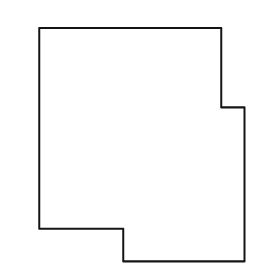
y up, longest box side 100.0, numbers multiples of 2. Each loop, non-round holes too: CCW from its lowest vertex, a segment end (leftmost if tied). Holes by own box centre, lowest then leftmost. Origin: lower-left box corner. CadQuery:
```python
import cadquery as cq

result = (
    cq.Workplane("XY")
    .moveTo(36.0, 0.0)
    .lineTo(88.0, 0.0)
    .lineTo(88.0, 66.0)
    .lineTo(78.0, 66.0)
    .lineTo(78.0, 100.0)
    .lineTo(0.0, 100.0)
    .lineTo(0.0, 14.0)
    .lineTo(36.0, 14.0)
    .close()
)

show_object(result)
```